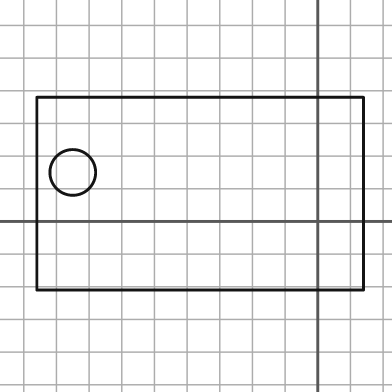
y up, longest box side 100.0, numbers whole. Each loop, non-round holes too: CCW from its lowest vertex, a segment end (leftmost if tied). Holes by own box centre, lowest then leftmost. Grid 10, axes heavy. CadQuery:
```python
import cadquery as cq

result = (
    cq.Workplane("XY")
    .moveTo(-86.0, -21.0)
    .lineTo(14.0, -21.0)
    .lineTo(14.0, 38.0)
    .lineTo(-86.0, 38.0)
    .close()
    .moveTo(-75.0, 15.0)
    .circle(7.0)
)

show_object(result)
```